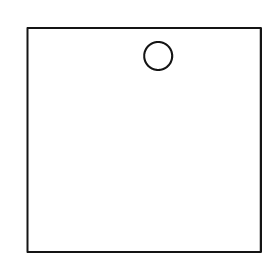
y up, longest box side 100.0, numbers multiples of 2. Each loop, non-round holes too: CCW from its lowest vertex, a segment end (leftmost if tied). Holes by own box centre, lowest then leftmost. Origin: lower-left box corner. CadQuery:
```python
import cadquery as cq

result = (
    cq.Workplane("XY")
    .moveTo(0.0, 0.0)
    .lineTo(100.0, 0.0)
    .lineTo(100.0, 96.0)
    .lineTo(0.0, 96.0)
    .close()
    .moveTo(56.0, 84.0)
    .circle(6.0)
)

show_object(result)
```